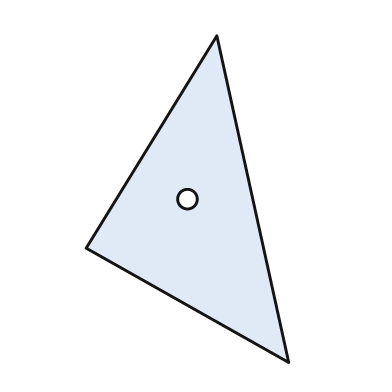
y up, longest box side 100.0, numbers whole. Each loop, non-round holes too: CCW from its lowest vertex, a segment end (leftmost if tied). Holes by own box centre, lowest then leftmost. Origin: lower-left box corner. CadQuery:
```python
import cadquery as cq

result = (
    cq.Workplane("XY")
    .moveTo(62.0, 0.0)
    .lineTo(40.0, 100.0)
    .lineTo(0.0, 35.0)
    .close()
    .moveTo(31.0, 50.0)
    .circle(3.0)
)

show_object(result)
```